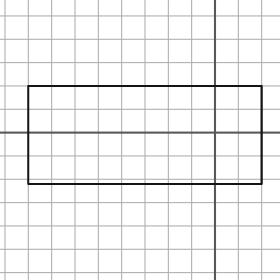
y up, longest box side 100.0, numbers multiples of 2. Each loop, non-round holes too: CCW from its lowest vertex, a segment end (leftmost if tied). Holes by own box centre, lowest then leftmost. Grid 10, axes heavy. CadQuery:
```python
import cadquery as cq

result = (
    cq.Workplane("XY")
    .moveTo(-80.0, -22.0)
    .lineTo(20.0, -22.0)
    .lineTo(20.0, 20.0)
    .lineTo(-80.0, 20.0)
    .close()
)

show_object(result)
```